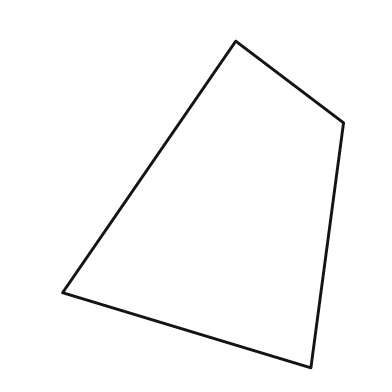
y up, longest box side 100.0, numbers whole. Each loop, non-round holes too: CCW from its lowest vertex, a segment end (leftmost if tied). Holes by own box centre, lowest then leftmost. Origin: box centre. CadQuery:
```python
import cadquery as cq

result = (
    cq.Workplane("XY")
    .moveTo(33.0, -50.0)
    .lineTo(43.0, 25.0)
    .lineTo(10.0, 50.0)
    .lineTo(-43.0, -27.0)
    .close()
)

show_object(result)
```